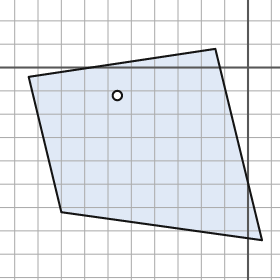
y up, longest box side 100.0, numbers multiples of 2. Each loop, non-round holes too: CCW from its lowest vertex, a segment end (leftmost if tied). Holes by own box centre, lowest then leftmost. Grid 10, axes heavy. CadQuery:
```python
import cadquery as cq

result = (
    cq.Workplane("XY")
    .moveTo(6.0, -74.0)
    .lineTo(-14.0, 8.0)
    .lineTo(-94.0, -4.0)
    .lineTo(-80.0, -62.0)
    .close()
    .moveTo(-56.0, -12.0)
    .circle(2.0)
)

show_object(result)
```